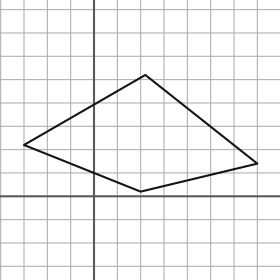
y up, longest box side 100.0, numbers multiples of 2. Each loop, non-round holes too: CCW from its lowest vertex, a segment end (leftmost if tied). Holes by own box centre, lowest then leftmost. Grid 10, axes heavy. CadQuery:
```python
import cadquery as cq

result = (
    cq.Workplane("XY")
    .moveTo(20.0, 2.0)
    .lineTo(70.0, 14.0)
    .lineTo(22.0, 52.0)
    .lineTo(-30.0, 22.0)
    .close()
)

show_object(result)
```